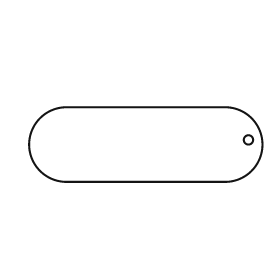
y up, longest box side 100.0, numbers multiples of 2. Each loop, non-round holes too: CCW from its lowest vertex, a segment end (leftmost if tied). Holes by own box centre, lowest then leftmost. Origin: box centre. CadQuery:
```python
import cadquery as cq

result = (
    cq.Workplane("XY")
    .moveTo(-34.0, -16.0)
    .lineTo(34.0, -16.0)
    .threePointArc((50.0, 0.0), (34.0, 16.0))
    .lineTo(-34.0, 16.0)
    .threePointArc((-50.0, 0.0), (-34.0, -16.0))
    .close()
    .moveTo(44.0, 2.0)
    .circle(2.0)
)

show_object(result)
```